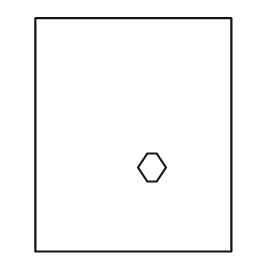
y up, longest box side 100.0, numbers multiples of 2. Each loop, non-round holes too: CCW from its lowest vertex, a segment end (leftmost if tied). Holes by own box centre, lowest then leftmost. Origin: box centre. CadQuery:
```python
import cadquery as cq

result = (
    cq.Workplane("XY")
    .moveTo(-42.0, -50.0)
    .lineTo(42.0, -50.0)
    .lineTo(42.0, 50.0)
    .lineTo(-42.0, 50.0)
    .close()
    .moveTo(6.0, -20.0)
    .lineTo(10.0, -20.0)
    .lineTo(14.0, -14.0)
    .lineTo(10.0, -8.0)
    .lineTo(6.0, -8.0)
    .lineTo(2.0, -14.0)
    .close()
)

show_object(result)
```